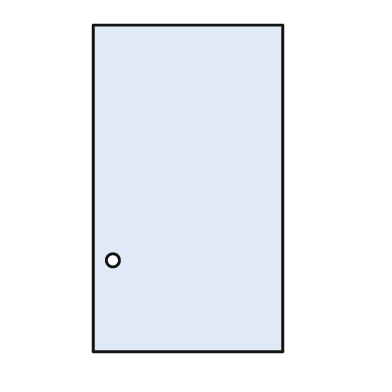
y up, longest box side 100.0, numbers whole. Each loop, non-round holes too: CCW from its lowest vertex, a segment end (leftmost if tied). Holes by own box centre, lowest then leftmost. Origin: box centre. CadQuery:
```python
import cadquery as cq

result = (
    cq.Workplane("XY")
    .moveTo(-29.0, -50.0)
    .lineTo(29.0, -50.0)
    .lineTo(29.0, 50.0)
    .lineTo(-29.0, 50.0)
    .close()
    .moveTo(-23.0, -22.0)
    .circle(2.0)
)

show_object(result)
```